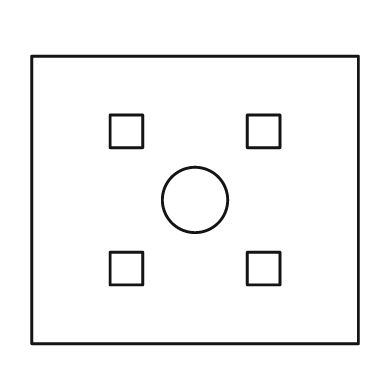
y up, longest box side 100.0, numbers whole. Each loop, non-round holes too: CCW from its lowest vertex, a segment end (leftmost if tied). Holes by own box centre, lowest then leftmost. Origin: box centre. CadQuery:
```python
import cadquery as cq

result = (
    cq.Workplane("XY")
    .moveTo(-50.0, -44.0)
    .lineTo(50.0, -44.0)
    .lineTo(50.0, 44.0)
    .lineTo(-50.0, 44.0)
    .close()
    .moveTo(-26.0, -26.0)
    .lineTo(-16.0, -26.0)
    .lineTo(-16.0, -16.0)
    .lineTo(-26.0, -16.0)
    .close()
    .moveTo(16.0, -26.0)
    .lineTo(26.0, -26.0)
    .lineTo(26.0, -16.0)
    .lineTo(16.0, -16.0)
    .close()
    .moveTo(0.0, 0.0)
    .circle(10.0)
    .moveTo(-26.0, 16.0)
    .lineTo(-16.0, 16.0)
    .lineTo(-16.0, 26.0)
    .lineTo(-26.0, 26.0)
    .close()
    .moveTo(16.0, 16.0)
    .lineTo(26.0, 16.0)
    .lineTo(26.0, 26.0)
    .lineTo(16.0, 26.0)
    .close()
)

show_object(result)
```